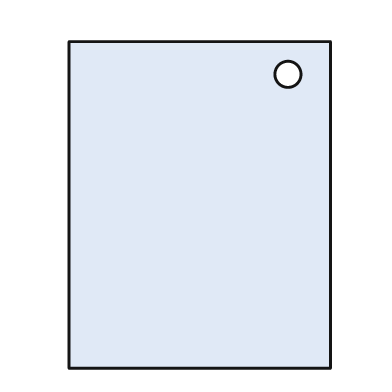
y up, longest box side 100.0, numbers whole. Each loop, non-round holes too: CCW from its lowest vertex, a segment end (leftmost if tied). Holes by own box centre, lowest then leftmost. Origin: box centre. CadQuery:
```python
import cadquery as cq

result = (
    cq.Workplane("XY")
    .moveTo(-40.0, -50.0)
    .lineTo(40.0, -50.0)
    .lineTo(40.0, 50.0)
    .lineTo(-40.0, 50.0)
    .close()
    .moveTo(27.0, 40.0)
    .circle(4.0)
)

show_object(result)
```